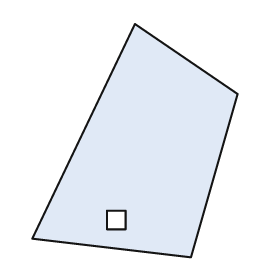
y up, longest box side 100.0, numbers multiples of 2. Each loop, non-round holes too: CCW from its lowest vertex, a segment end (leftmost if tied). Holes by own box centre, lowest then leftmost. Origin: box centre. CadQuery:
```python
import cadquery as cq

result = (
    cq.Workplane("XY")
    .moveTo(24.0, -50.0)
    .lineTo(44.0, 20.0)
    .lineTo(0.0, 50.0)
    .lineTo(-44.0, -42.0)
    .close()
    .moveTo(-12.0, -38.0)
    .lineTo(-4.0, -38.0)
    .lineTo(-4.0, -30.0)
    .lineTo(-12.0, -30.0)
    .close()
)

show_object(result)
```